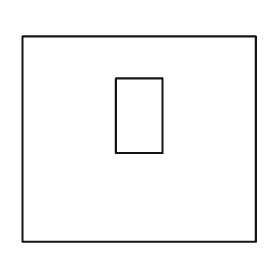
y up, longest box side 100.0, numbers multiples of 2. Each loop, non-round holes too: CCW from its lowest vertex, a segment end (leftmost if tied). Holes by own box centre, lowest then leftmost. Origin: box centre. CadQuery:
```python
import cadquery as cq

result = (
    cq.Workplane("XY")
    .moveTo(-50.0, -44.0)
    .lineTo(50.0, -44.0)
    .lineTo(50.0, 44.0)
    .lineTo(-50.0, 44.0)
    .close()
    .moveTo(-10.0, -6.0)
    .lineTo(10.0, -6.0)
    .lineTo(10.0, 26.0)
    .lineTo(-10.0, 26.0)
    .close()
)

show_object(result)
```